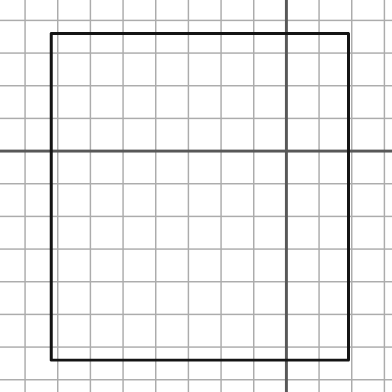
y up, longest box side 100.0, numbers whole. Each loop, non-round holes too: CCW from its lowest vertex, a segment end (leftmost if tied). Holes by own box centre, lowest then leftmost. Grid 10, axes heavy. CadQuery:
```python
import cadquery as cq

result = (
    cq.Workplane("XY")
    .moveTo(-72.0, -64.0)
    .lineTo(19.0, -64.0)
    .lineTo(19.0, 36.0)
    .lineTo(-72.0, 36.0)
    .close()
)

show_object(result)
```